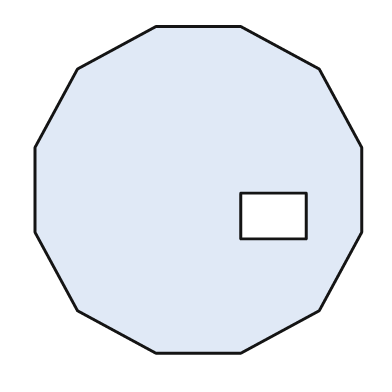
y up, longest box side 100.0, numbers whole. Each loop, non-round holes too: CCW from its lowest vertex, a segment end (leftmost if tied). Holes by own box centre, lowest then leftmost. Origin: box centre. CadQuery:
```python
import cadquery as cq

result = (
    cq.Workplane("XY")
    .moveTo(-13.0, -50.0)
    .lineTo(13.0, -50.0)
    .lineTo(37.0, -37.0)
    .lineTo(50.0, -13.0)
    .lineTo(50.0, 13.0)
    .lineTo(37.0, 37.0)
    .lineTo(13.0, 50.0)
    .lineTo(-13.0, 50.0)
    .lineTo(-37.0, 37.0)
    .lineTo(-50.0, 13.0)
    .lineTo(-50.0, -13.0)
    .lineTo(-37.0, -37.0)
    .close()
    .moveTo(13.0, -15.0)
    .lineTo(33.0, -15.0)
    .lineTo(33.0, -1.0)
    .lineTo(13.0, -1.0)
    .close()
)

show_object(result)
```